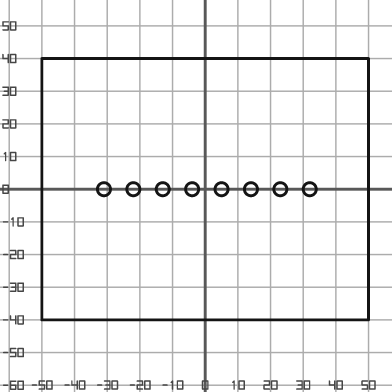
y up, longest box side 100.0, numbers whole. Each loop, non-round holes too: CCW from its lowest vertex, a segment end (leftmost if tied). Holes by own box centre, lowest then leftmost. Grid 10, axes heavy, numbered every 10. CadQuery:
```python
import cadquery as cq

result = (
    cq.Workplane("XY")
    .moveTo(-50.0, -40.0)
    .lineTo(50.0, -40.0)
    .lineTo(50.0, 40.0)
    .lineTo(-50.0, 40.0)
    .close()
    .moveTo(-31.0, 0.0)
    .circle(2.0)
    .moveTo(-22.0, 0.0)
    .circle(2.0)
    .moveTo(-13.0, 0.0)
    .circle(2.0)
    .moveTo(-4.0, 0.0)
    .circle(2.0)
    .moveTo(5.0, 0.0)
    .circle(2.0)
    .moveTo(14.0, 0.0)
    .circle(2.0)
    .moveTo(23.0, 0.0)
    .circle(2.0)
    .moveTo(32.0, 0.0)
    .circle(2.0)
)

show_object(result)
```